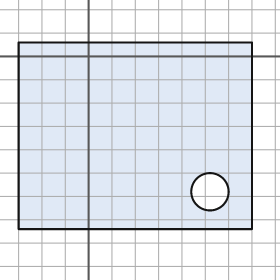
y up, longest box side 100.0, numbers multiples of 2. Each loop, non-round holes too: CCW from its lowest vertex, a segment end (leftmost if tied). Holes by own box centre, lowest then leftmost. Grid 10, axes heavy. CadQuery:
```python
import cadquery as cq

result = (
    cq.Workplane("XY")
    .moveTo(-30.0, -74.0)
    .lineTo(70.0, -74.0)
    .lineTo(70.0, 6.0)
    .lineTo(-30.0, 6.0)
    .close()
    .moveTo(52.0, -58.0)
    .circle(8.0)
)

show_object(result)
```